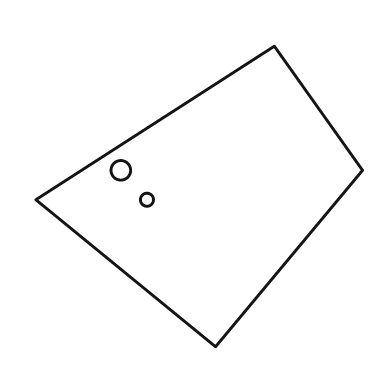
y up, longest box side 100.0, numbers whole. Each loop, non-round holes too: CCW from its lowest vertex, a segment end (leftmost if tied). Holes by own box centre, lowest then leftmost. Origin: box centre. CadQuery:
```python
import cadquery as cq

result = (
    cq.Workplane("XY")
    .moveTo(5.0, -46.0)
    .lineTo(50.0, 8.0)
    .lineTo(23.0, 46.0)
    .lineTo(-50.0, -1.0)
    .close()
    .moveTo(-16.0, -1.0)
    .circle(2.0)
    .moveTo(-24.0, 8.0)
    .circle(3.0)
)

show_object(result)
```